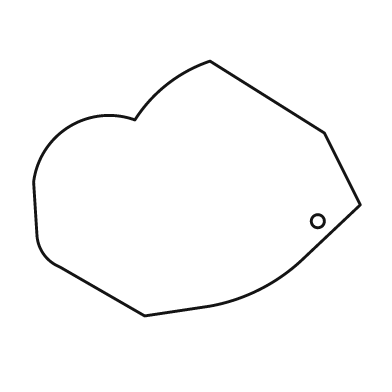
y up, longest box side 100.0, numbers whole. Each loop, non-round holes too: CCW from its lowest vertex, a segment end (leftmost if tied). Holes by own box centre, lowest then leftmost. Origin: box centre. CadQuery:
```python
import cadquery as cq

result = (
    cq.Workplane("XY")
    .moveTo(-16.0, -39.0)
    .lineTo(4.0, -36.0)
    .threePointArc((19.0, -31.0), (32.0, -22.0))
    .lineTo(50.0, -5.0)
    .lineTo(39.0, 17.0)
    .lineTo(4.0, 39.0)
    .threePointArc((-9.0, 32.0), (-19.0, 21.0))
    .threePointArc((-39.0, 19.0), (-50.0, 2.0))
    .lineTo(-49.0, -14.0)
    .threePointArc((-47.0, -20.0), (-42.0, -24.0))
    .close()
    .moveTo(37.0, -10.0)
    .circle(2.0)
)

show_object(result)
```